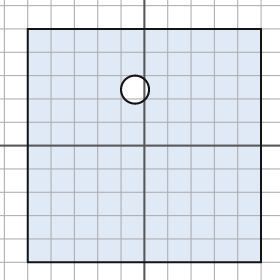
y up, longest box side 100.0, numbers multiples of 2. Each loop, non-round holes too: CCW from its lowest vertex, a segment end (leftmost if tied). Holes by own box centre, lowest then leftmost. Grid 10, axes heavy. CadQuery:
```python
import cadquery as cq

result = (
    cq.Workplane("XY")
    .moveTo(-50.0, -50.0)
    .lineTo(50.0, -50.0)
    .lineTo(50.0, 50.0)
    .lineTo(-50.0, 50.0)
    .close()
    .moveTo(-4.0, 24.0)
    .circle(6.0)
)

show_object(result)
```